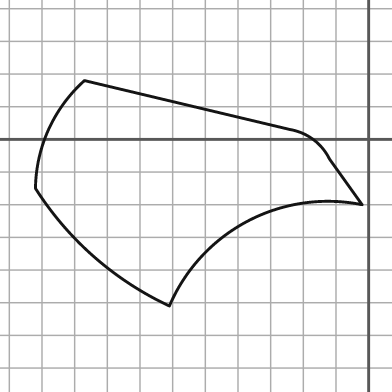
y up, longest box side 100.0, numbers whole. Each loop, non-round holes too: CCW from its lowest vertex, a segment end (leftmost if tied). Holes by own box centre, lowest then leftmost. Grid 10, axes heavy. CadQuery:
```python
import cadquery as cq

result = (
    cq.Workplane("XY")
    .moveTo(-61.0, -51.0)
    .threePointArc((-37.0, -25.0), (-2.0, -20.0))
    .lineTo(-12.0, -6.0)
    .threePointArc((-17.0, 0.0), (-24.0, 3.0))
    .lineTo(-87.0, 18.0)
    .threePointArc((-98.0, 3.0), (-102.0, -15.0))
    .threePointArc((-84.0, -36.0), (-61.0, -51.0))
    .close()
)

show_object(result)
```